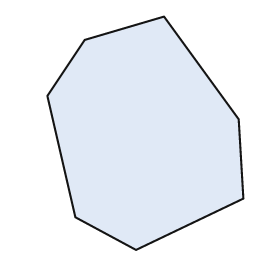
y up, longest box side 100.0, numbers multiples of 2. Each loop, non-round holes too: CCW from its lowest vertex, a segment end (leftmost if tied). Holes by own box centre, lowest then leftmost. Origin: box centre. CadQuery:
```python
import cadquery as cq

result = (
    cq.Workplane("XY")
    .moveTo(-4.0, -50.0)
    .lineTo(42.0, -28.0)
    .lineTo(40.0, 6.0)
    .lineTo(8.0, 50.0)
    .lineTo(-26.0, 40.0)
    .lineTo(-42.0, 16.0)
    .lineTo(-30.0, -36.0)
    .close()
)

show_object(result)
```